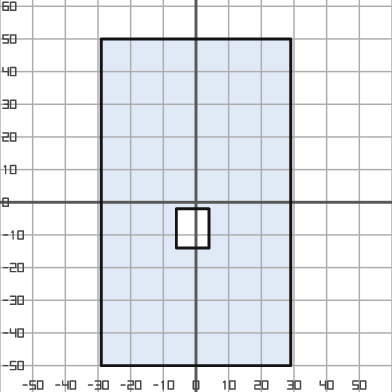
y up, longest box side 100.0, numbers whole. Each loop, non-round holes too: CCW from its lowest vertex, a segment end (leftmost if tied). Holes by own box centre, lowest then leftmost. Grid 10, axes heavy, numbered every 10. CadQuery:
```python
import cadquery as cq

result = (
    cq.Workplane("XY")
    .moveTo(-29.0, -50.0)
    .lineTo(29.0, -50.0)
    .lineTo(29.0, 50.0)
    .lineTo(-29.0, 50.0)
    .close()
    .moveTo(-6.0, -14.0)
    .lineTo(4.0, -14.0)
    .lineTo(4.0, -2.0)
    .lineTo(-6.0, -2.0)
    .close()
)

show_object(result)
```